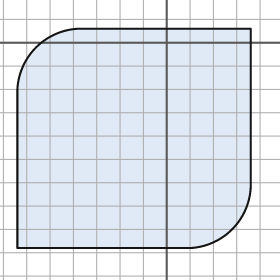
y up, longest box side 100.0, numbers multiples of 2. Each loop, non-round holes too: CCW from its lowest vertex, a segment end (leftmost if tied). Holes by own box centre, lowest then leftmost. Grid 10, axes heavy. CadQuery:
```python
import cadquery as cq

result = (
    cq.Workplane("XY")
    .moveTo(-64.0, -88.0)
    .lineTo(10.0, -88.0)
    .threePointArc((28.0, -80.0), (36.0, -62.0))
    .lineTo(36.0, 6.0)
    .lineTo(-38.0, 6.0)
    .threePointArc((-56.0, -2.0), (-64.0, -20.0))
    .close()
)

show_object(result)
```